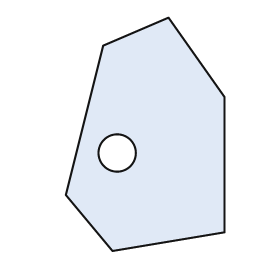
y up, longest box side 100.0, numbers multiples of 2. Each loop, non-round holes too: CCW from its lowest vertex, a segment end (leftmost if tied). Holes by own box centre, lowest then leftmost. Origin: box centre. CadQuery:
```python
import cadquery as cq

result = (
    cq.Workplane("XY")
    .moveTo(-14.0, -50.0)
    .lineTo(34.0, -42.0)
    .lineTo(34.0, 16.0)
    .lineTo(10.0, 50.0)
    .lineTo(-18.0, 38.0)
    .lineTo(-34.0, -26.0)
    .close()
    .moveTo(-12.0, -8.0)
    .circle(8.0)
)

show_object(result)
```